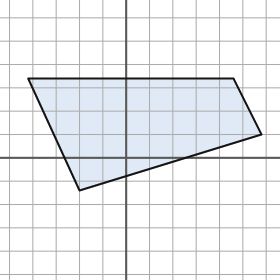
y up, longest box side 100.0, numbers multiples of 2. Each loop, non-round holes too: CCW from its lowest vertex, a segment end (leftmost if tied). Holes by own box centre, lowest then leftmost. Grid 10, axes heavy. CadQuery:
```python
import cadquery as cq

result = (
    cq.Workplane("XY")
    .moveTo(-20.0, -14.0)
    .lineTo(58.0, 10.0)
    .lineTo(46.0, 34.0)
    .lineTo(-42.0, 34.0)
    .close()
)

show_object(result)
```